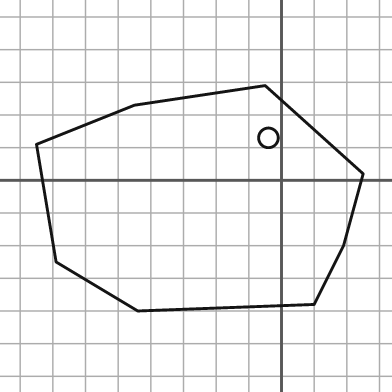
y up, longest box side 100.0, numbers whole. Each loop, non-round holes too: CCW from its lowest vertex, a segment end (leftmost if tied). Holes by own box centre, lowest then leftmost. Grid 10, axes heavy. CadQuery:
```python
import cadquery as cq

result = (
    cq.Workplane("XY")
    .moveTo(-44.0, -40.0)
    .lineTo(10.0, -38.0)
    .lineTo(19.0, -20.0)
    .lineTo(25.0, 2.0)
    .lineTo(-5.0, 29.0)
    .lineTo(-45.0, 23.0)
    .lineTo(-75.0, 11.0)
    .lineTo(-69.0, -25.0)
    .close()
    .moveTo(-4.0, 13.0)
    .circle(3.0)
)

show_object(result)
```